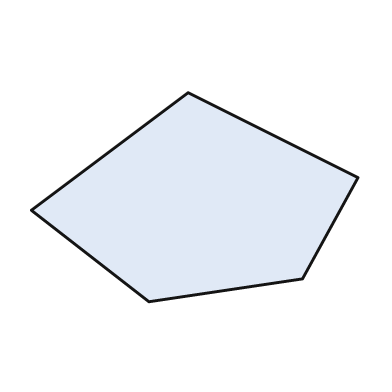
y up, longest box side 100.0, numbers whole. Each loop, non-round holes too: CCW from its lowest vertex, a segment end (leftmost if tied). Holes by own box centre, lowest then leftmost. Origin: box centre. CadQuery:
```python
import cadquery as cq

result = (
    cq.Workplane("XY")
    .moveTo(-14.0, -32.0)
    .lineTo(33.0, -25.0)
    .lineTo(50.0, 6.0)
    .lineTo(-2.0, 32.0)
    .lineTo(-50.0, -4.0)
    .close()
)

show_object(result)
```